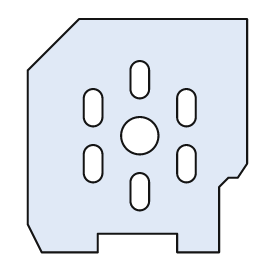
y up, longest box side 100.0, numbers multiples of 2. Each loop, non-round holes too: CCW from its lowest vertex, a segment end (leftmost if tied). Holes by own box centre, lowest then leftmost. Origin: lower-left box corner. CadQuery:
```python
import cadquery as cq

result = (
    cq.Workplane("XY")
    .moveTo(6.0, 0.0)
    .lineTo(30.0, 0.0)
    .lineTo(30.0, 8.0)
    .lineTo(64.0, 8.0)
    .lineTo(64.0, 0.0)
    .lineTo(82.0, 0.0)
    .lineTo(82.0, 28.0)
    .lineTo(86.0, 32.0)
    .lineTo(90.0, 32.0)
    .lineTo(94.0, 38.0)
    .lineTo(94.0, 100.0)
    .lineTo(22.0, 100.0)
    .lineTo(0.0, 78.0)
    .lineTo(0.0, 12.0)
    .close()
    .moveTo(44.0, 22.0)
    .threePointArc((48.0, 18.0), (52.0, 22.0))
    .lineTo(52.0, 30.0)
    .threePointArc((48.0, 34.0), (44.0, 30.0))
    .close()
    .moveTo(24.0, 34.0)
    .threePointArc((28.0, 30.0), (32.0, 34.0))
    .lineTo(32.0, 42.0)
    .threePointArc((28.0, 46.0), (24.0, 42.0))
    .close()
    .moveTo(64.0, 34.0)
    .threePointArc((68.0, 30.0), (72.0, 34.0))
    .lineTo(72.0, 42.0)
    .threePointArc((68.0, 46.0), (64.0, 42.0))
    .close()
    .moveTo(48.0, 50.0)
    .circle(8.0)
    .moveTo(24.0, 58.0)
    .threePointArc((28.0, 54.0), (32.0, 58.0))
    .lineTo(32.0, 66.0)
    .threePointArc((28.0, 70.0), (24.0, 66.0))
    .close()
    .moveTo(64.0, 58.0)
    .threePointArc((68.0, 54.0), (72.0, 58.0))
    .lineTo(72.0, 66.0)
    .threePointArc((68.0, 70.0), (64.0, 66.0))
    .close()
    .moveTo(44.0, 70.0)
    .threePointArc((48.0, 66.0), (52.0, 70.0))
    .lineTo(52.0, 78.0)
    .threePointArc((48.0, 82.0), (44.0, 78.0))
    .close()
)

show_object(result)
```